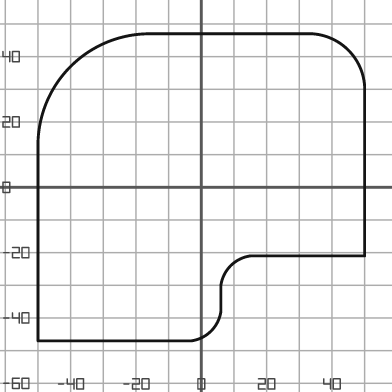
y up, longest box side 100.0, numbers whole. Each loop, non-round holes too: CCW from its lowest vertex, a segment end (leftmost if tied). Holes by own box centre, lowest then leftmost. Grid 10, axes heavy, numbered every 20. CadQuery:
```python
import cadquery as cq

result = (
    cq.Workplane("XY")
    .moveTo(-50.0, -47.0)
    .lineTo(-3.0, -47.0)
    .threePointArc((3.0, -44.0), (6.0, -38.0))
    .lineTo(6.0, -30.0)
    .threePointArc((9.0, -24.0), (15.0, -21.0))
    .lineTo(50.0, -21.0)
    .lineTo(50.0, 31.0)
    .threePointArc((45.0, 42.0), (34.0, 47.0))
    .lineTo(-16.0, 47.0)
    .threePointArc((-40.0, 37.0), (-50.0, 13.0))
    .close()
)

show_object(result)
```